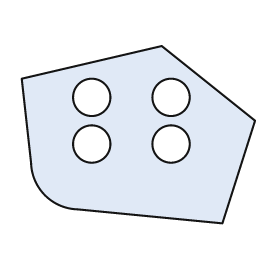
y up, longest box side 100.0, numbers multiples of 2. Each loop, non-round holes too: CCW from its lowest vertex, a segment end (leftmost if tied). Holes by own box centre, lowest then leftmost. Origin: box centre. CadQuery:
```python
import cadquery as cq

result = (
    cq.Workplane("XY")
    .moveTo(36.0, -38.0)
    .lineTo(50.0, 6.0)
    .lineTo(10.0, 38.0)
    .lineTo(-50.0, 24.0)
    .lineTo(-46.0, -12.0)
    .threePointArc((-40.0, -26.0), (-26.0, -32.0))
    .close()
    .moveTo(-20.0, -4.0)
    .circle(8.0)
    .moveTo(14.0, -4.0)
    .circle(8.0)
    .moveTo(-20.0, 16.0)
    .circle(8.0)
    .moveTo(14.0, 16.0)
    .circle(8.0)
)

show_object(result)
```